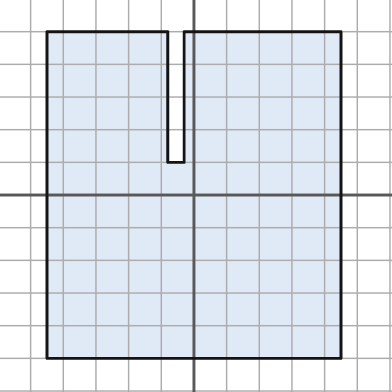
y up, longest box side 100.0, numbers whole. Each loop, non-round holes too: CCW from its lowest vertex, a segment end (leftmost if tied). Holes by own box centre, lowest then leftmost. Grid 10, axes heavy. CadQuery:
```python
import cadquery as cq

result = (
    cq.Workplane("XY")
    .moveTo(-45.0, -50.0)
    .lineTo(45.0, -50.0)
    .lineTo(45.0, 50.0)
    .lineTo(-3.0, 50.0)
    .lineTo(-3.0, 10.0)
    .lineTo(-8.0, 10.0)
    .lineTo(-8.0, 50.0)
    .lineTo(-45.0, 50.0)
    .close()
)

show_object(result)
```